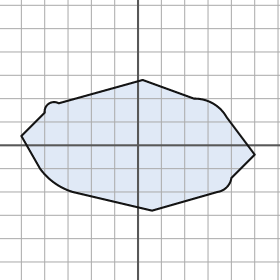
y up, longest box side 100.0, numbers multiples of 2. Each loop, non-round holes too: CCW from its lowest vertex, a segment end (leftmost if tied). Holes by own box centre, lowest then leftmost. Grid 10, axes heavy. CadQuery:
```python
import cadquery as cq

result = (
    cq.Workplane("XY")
    .moveTo(6.0, -28.0)
    .lineTo(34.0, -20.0)
    .threePointArc((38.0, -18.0), (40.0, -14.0))
    .lineTo(50.0, -4.0)
    .lineTo(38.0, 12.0)
    .threePointArc((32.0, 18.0), (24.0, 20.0))
    .lineTo(2.0, 28.0)
    .lineTo(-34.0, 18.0)
    .threePointArc((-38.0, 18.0), (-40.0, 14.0))
    .lineTo(-50.0, 4.0)
    .lineTo(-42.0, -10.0)
    .threePointArc((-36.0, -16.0), (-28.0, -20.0))
    .close()
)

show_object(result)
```